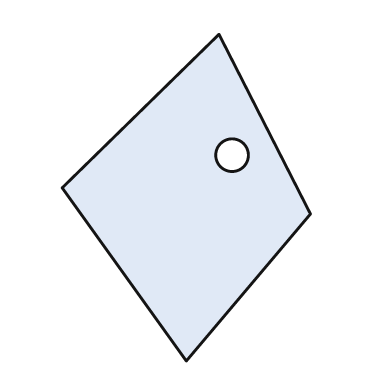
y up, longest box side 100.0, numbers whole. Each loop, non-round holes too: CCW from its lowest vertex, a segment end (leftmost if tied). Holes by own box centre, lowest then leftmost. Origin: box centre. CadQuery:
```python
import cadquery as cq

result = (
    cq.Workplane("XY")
    .moveTo(0.0, -50.0)
    .lineTo(38.0, -5.0)
    .lineTo(10.0, 50.0)
    .lineTo(-38.0, 3.0)
    .close()
    .moveTo(14.0, 13.0)
    .circle(5.0)
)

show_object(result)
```